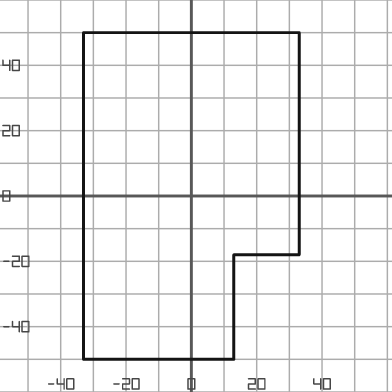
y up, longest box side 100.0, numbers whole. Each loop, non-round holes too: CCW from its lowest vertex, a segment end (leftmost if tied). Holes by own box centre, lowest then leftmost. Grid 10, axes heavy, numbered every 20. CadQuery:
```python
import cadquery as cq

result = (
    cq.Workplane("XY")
    .moveTo(-33.0, -50.0)
    .lineTo(13.0, -50.0)
    .lineTo(13.0, -18.0)
    .lineTo(33.0, -18.0)
    .lineTo(33.0, 50.0)
    .lineTo(-33.0, 50.0)
    .close()
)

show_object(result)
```